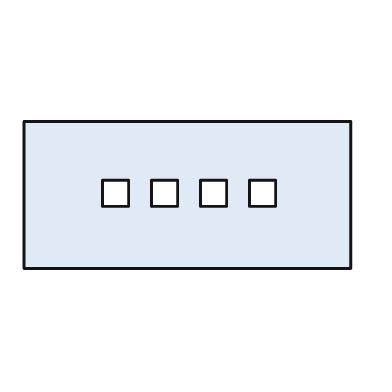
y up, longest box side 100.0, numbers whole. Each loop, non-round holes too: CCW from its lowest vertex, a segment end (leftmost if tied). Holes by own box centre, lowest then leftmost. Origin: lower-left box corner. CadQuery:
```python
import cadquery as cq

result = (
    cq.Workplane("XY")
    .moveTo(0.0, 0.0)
    .lineTo(100.0, 0.0)
    .lineTo(100.0, 45.0)
    .lineTo(0.0, 45.0)
    .close()
    .moveTo(24.0, 19.0)
    .lineTo(32.0, 19.0)
    .lineTo(32.0, 27.0)
    .lineTo(24.0, 27.0)
    .close()
    .moveTo(39.0, 19.0)
    .lineTo(47.0, 19.0)
    .lineTo(47.0, 27.0)
    .lineTo(39.0, 27.0)
    .close()
    .moveTo(54.0, 19.0)
    .lineTo(62.0, 19.0)
    .lineTo(62.0, 27.0)
    .lineTo(54.0, 27.0)
    .close()
    .moveTo(69.0, 19.0)
    .lineTo(77.0, 19.0)
    .lineTo(77.0, 27.0)
    .lineTo(69.0, 27.0)
    .close()
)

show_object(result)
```